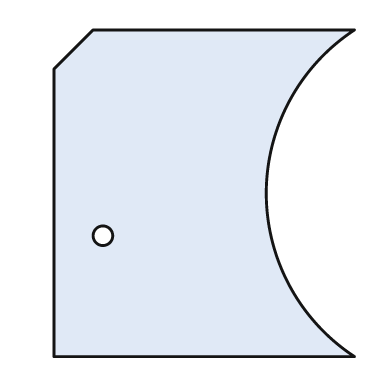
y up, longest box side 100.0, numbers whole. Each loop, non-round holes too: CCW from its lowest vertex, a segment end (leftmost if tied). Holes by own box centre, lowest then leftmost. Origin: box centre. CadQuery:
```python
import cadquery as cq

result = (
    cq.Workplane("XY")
    .moveTo(-46.0, -50.0)
    .lineTo(46.0, -50.0)
    .threePointArc((19.0, 0.0), (46.0, 50.0))
    .lineTo(-34.0, 50.0)
    .lineTo(-46.0, 38.0)
    .close()
    .moveTo(-31.0, -13.0)
    .circle(3.0)
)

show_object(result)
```